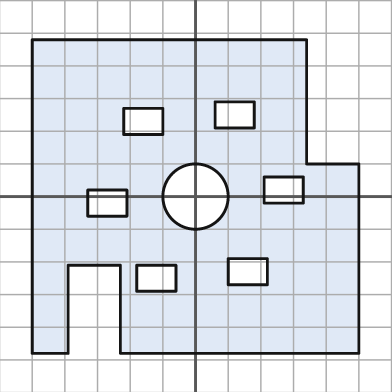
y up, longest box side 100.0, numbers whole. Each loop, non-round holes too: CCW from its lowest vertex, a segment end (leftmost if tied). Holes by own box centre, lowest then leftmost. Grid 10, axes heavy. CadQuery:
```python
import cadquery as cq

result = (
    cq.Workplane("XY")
    .moveTo(-50.0, -48.0)
    .lineTo(-39.0, -48.0)
    .lineTo(-39.0, -21.0)
    .lineTo(-23.0, -21.0)
    .lineTo(-23.0, -48.0)
    .lineTo(50.0, -48.0)
    .lineTo(50.0, 10.0)
    .lineTo(34.0, 10.0)
    .lineTo(34.0, 48.0)
    .lineTo(-50.0, 48.0)
    .close()
    .moveTo(-18.0, -29.0)
    .lineTo(-6.0, -29.0)
    .lineTo(-6.0, -21.0)
    .lineTo(-18.0, -21.0)
    .close()
    .moveTo(10.0, -27.0)
    .lineTo(22.0, -27.0)
    .lineTo(22.0, -19.0)
    .lineTo(10.0, -19.0)
    .close()
    .moveTo(-33.0, -6.0)
    .lineTo(-21.0, -6.0)
    .lineTo(-21.0, 2.0)
    .lineTo(-33.0, 2.0)
    .close()
    .moveTo(0.0, 0.0)
    .circle(10.0)
    .moveTo(21.0, -2.0)
    .lineTo(33.0, -2.0)
    .lineTo(33.0, 6.0)
    .lineTo(21.0, 6.0)
    .close()
    .moveTo(-22.0, 19.0)
    .lineTo(-10.0, 19.0)
    .lineTo(-10.0, 27.0)
    .lineTo(-22.0, 27.0)
    .close()
    .moveTo(6.0, 21.0)
    .lineTo(18.0, 21.0)
    .lineTo(18.0, 29.0)
    .lineTo(6.0, 29.0)
    .close()
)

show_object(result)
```